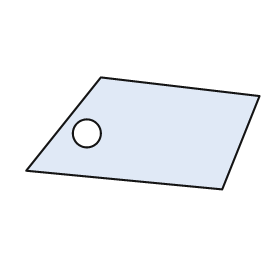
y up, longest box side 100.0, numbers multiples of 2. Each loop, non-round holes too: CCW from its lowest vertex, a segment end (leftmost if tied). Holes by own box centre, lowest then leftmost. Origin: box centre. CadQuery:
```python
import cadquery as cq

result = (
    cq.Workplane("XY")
    .moveTo(34.0, -24.0)
    .lineTo(50.0, 16.0)
    .lineTo(-18.0, 24.0)
    .lineTo(-50.0, -16.0)
    .close()
    .moveTo(-24.0, 0.0)
    .circle(6.0)
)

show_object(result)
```